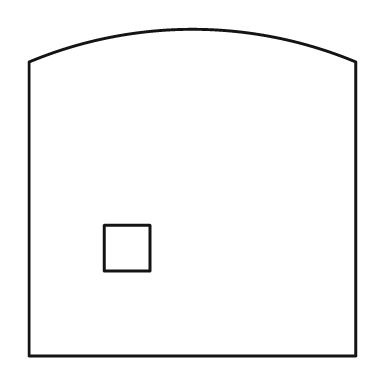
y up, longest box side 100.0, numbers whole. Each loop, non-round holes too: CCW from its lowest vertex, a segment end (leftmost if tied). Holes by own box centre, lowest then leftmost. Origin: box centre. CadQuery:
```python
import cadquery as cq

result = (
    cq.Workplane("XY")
    .moveTo(-50.0, -50.0)
    .lineTo(50.0, -50.0)
    .lineTo(50.0, 40.0)
    .threePointArc((0.0, 50.0), (-50.0, 40.0))
    .close()
    .moveTo(-27.0, -24.0)
    .lineTo(-13.0, -24.0)
    .lineTo(-13.0, -10.0)
    .lineTo(-27.0, -10.0)
    .close()
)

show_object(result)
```